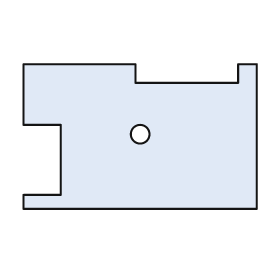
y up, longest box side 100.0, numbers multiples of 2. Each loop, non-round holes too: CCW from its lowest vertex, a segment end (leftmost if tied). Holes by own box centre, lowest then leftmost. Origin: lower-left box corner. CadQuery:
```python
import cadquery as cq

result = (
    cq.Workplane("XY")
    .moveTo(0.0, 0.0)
    .lineTo(100.0, 0.0)
    .lineTo(100.0, 62.0)
    .lineTo(92.0, 62.0)
    .lineTo(92.0, 54.0)
    .lineTo(48.0, 54.0)
    .lineTo(48.0, 62.0)
    .lineTo(0.0, 62.0)
    .lineTo(0.0, 36.0)
    .lineTo(16.0, 36.0)
    .lineTo(16.0, 6.0)
    .lineTo(0.0, 6.0)
    .close()
    .moveTo(50.0, 32.0)
    .circle(4.0)
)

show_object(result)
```